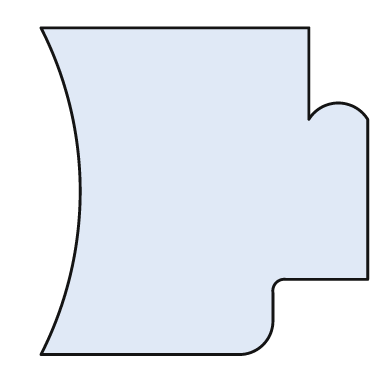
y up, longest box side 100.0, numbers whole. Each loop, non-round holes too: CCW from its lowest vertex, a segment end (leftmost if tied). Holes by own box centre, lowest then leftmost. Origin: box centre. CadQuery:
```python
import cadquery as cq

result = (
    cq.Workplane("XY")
    .moveTo(-50.0, -50.0)
    .lineTo(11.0, -50.0)
    .threePointArc((18.0, -47.0), (21.0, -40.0))
    .lineTo(21.0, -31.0)
    .threePointArc((22.0, -28.0), (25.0, -27.0))
    .lineTo(50.0, -27.0)
    .lineTo(50.0, 22.0)
    .threePointArc((41.0, 27.0), (32.0, 22.0))
    .lineTo(32.0, 50.0)
    .lineTo(-50.0, 50.0)
    .threePointArc((-38.0, 0.0), (-50.0, -50.0))
    .close()
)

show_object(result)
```